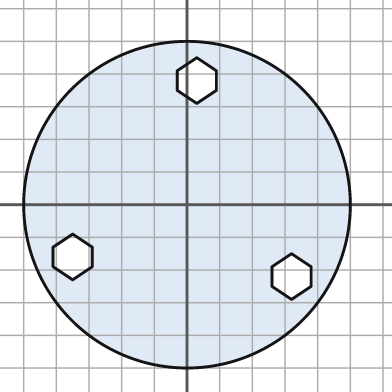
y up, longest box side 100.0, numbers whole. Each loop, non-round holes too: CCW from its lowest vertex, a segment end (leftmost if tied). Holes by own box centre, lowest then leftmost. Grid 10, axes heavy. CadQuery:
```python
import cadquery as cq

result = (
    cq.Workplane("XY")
    .moveTo(0.0, 0.0)
    .circle(50.0)
    .moveTo(32.0, -29.0)
    .lineTo(38.0, -25.0)
    .lineTo(38.0, -19.0)
    .lineTo(32.0, -15.0)
    .lineTo(26.0, -19.0)
    .lineTo(26.0, -25.0)
    .close()
    .moveTo(-35.0, -23.0)
    .lineTo(-29.0, -19.0)
    .lineTo(-29.0, -13.0)
    .lineTo(-35.0, -9.0)
    .lineTo(-41.0, -13.0)
    .lineTo(-41.0, -19.0)
    .close()
    .moveTo(3.0, 31.0)
    .lineTo(9.0, 35.0)
    .lineTo(9.0, 41.0)
    .lineTo(3.0, 45.0)
    .lineTo(-3.0, 41.0)
    .lineTo(-3.0, 35.0)
    .close()
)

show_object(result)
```